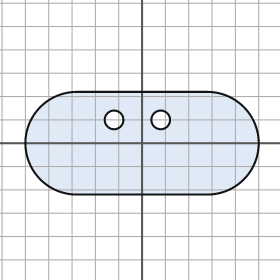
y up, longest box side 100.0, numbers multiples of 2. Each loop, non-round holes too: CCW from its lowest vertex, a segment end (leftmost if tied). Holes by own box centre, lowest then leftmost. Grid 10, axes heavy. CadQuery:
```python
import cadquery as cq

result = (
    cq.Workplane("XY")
    .moveTo(-28.0, -22.0)
    .lineTo(28.0, -22.0)
    .threePointArc((50.0, 0.0), (28.0, 22.0))
    .lineTo(-28.0, 22.0)
    .threePointArc((-50.0, 0.0), (-28.0, -22.0))
    .close()
    .moveTo(-12.0, 10.0)
    .circle(4.0)
    .moveTo(8.0, 10.0)
    .circle(4.0)
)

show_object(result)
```